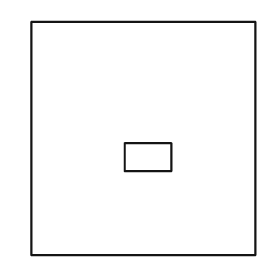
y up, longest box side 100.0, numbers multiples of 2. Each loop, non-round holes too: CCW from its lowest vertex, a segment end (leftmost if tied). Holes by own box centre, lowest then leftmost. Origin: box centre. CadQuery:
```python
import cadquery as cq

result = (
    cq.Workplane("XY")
    .moveTo(-48.0, -50.0)
    .lineTo(48.0, -50.0)
    .lineTo(48.0, 50.0)
    .lineTo(-48.0, 50.0)
    .close()
    .moveTo(-8.0, -14.0)
    .lineTo(12.0, -14.0)
    .lineTo(12.0, -2.0)
    .lineTo(-8.0, -2.0)
    .close()
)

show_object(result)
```